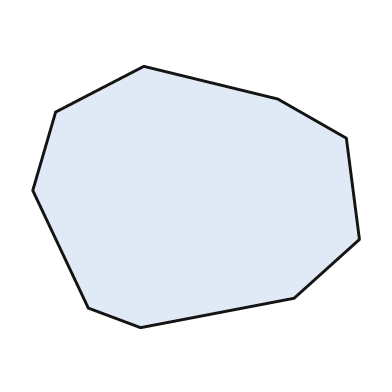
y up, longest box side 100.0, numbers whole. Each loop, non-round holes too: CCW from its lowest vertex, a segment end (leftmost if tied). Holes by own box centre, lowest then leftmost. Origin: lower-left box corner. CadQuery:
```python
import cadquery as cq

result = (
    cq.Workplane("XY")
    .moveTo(33.0, 0.0)
    .lineTo(80.0, 9.0)
    .lineTo(100.0, 27.0)
    .lineTo(96.0, 58.0)
    .lineTo(75.0, 70.0)
    .lineTo(34.0, 80.0)
    .lineTo(7.0, 66.0)
    .lineTo(0.0, 42.0)
    .lineTo(17.0, 6.0)
    .close()
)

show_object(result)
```